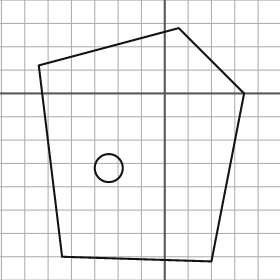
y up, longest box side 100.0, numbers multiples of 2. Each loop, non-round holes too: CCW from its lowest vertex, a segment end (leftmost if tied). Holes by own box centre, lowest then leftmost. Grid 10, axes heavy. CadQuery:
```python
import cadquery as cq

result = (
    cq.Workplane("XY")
    .moveTo(20.0, -72.0)
    .lineTo(34.0, 0.0)
    .lineTo(6.0, 28.0)
    .lineTo(-54.0, 12.0)
    .lineTo(-44.0, -70.0)
    .close()
    .moveTo(-24.0, -32.0)
    .circle(6.0)
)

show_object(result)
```